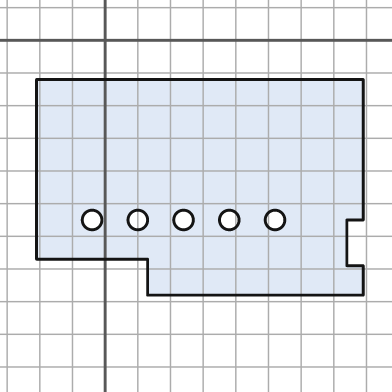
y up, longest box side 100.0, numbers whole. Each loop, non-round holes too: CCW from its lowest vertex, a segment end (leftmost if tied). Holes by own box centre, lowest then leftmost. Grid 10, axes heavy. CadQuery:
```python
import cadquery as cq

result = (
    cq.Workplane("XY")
    .moveTo(13.0, -78.0)
    .lineTo(79.0, -78.0)
    .lineTo(79.0, -69.0)
    .lineTo(74.0, -69.0)
    .lineTo(74.0, -55.0)
    .lineTo(79.0, -55.0)
    .lineTo(79.0, -12.0)
    .lineTo(-21.0, -12.0)
    .lineTo(-21.0, -67.0)
    .lineTo(13.0, -67.0)
    .close()
    .moveTo(-4.0, -55.0)
    .circle(3.0)
    .moveTo(10.0, -55.0)
    .circle(3.0)
    .moveTo(24.0, -55.0)
    .circle(3.0)
    .moveTo(38.0, -55.0)
    .circle(3.0)
    .moveTo(52.0, -55.0)
    .circle(3.0)
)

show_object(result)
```